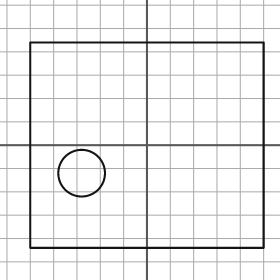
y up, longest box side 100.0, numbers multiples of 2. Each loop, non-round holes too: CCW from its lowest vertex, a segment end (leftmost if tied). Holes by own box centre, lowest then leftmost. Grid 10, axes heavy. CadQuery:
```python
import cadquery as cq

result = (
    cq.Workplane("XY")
    .moveTo(-50.0, -44.0)
    .lineTo(50.0, -44.0)
    .lineTo(50.0, 44.0)
    .lineTo(-50.0, 44.0)
    .close()
    .moveTo(-28.0, -12.0)
    .circle(10.0)
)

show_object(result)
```